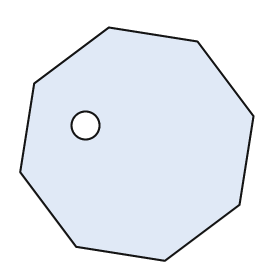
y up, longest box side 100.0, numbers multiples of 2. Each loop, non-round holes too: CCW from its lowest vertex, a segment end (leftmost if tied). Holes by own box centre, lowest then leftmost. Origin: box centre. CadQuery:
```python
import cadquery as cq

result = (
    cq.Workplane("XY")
    .moveTo(12.0, -50.0)
    .lineTo(44.0, -26.0)
    .lineTo(50.0, 12.0)
    .lineTo(26.0, 44.0)
    .lineTo(-12.0, 50.0)
    .lineTo(-44.0, 26.0)
    .lineTo(-50.0, -12.0)
    .lineTo(-26.0, -44.0)
    .close()
    .moveTo(-22.0, 8.0)
    .circle(6.0)
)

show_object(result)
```